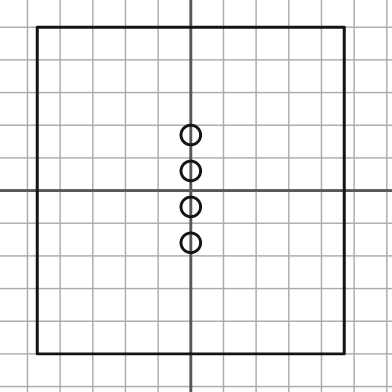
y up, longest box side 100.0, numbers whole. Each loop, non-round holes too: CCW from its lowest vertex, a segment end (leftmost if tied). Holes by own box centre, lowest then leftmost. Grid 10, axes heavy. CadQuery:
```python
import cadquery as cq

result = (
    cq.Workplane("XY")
    .moveTo(-47.0, -50.0)
    .lineTo(47.0, -50.0)
    .lineTo(47.0, 50.0)
    .lineTo(-47.0, 50.0)
    .close()
    .moveTo(0.0, -16.0)
    .circle(3.0)
    .moveTo(0.0, -5.0)
    .circle(3.0)
    .moveTo(0.0, 6.0)
    .circle(3.0)
    .moveTo(0.0, 17.0)
    .circle(3.0)
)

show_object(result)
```